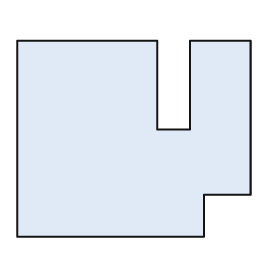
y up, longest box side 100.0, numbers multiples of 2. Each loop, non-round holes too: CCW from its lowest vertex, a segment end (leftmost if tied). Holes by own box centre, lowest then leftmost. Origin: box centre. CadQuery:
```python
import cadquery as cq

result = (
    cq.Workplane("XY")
    .moveTo(-50.0, -42.0)
    .lineTo(30.0, -42.0)
    .lineTo(30.0, -24.0)
    .lineTo(50.0, -24.0)
    .lineTo(50.0, 42.0)
    .lineTo(24.0, 42.0)
    .lineTo(24.0, 4.0)
    .lineTo(10.0, 4.0)
    .lineTo(10.0, 42.0)
    .lineTo(-50.0, 42.0)
    .close()
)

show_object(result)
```